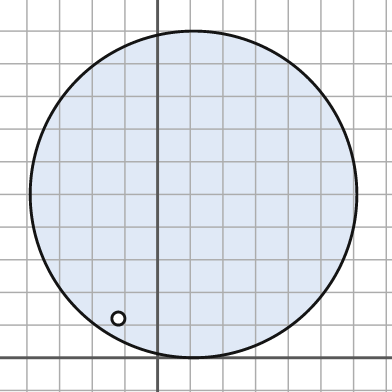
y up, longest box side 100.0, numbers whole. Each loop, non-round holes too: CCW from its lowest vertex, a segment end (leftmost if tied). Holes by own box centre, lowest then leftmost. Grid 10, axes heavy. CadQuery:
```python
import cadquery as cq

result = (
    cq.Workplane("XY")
    .moveTo(11.0, 50.0)
    .circle(50.0)
    .moveTo(-12.0, 12.0)
    .circle(2.0)
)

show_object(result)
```